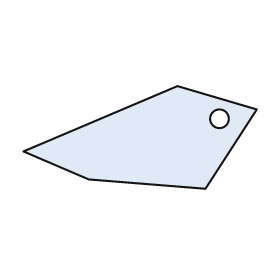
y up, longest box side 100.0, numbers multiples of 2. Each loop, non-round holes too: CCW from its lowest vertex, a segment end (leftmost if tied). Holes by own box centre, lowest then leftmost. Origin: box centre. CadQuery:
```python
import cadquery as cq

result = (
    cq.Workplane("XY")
    .moveTo(28.0, -22.0)
    .lineTo(50.0, 12.0)
    .lineTo(16.0, 22.0)
    .lineTo(-50.0, -6.0)
    .lineTo(-22.0, -18.0)
    .close()
    .moveTo(34.0, 8.0)
    .circle(4.0)
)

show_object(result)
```